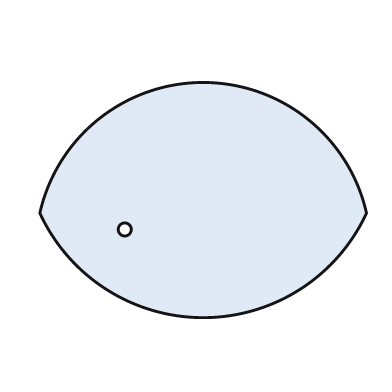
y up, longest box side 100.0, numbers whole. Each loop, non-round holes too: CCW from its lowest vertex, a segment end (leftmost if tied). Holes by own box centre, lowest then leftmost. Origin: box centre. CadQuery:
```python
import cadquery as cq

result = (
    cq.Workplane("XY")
    .moveTo(-50.0, -4.0)
    .threePointArc((0.0, -36.0), (50.0, -4.0))
    .threePointArc((0.0, 36.0), (-50.0, -4.0))
    .close()
    .moveTo(-24.0, -9.0)
    .circle(2.0)
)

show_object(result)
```